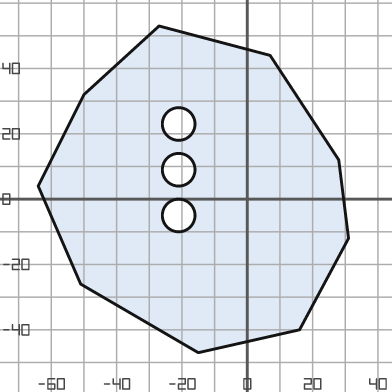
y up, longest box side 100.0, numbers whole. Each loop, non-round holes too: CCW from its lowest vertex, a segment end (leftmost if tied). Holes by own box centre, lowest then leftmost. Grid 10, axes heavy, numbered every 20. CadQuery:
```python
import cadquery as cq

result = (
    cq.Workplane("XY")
    .moveTo(-15.0, -47.0)
    .lineTo(16.0, -40.0)
    .lineTo(31.0, -12.0)
    .lineTo(28.0, 12.0)
    .lineTo(7.0, 44.0)
    .lineTo(-27.0, 53.0)
    .lineTo(-50.0, 32.0)
    .lineTo(-64.0, 4.0)
    .lineTo(-51.0, -26.0)
    .close()
    .moveTo(-21.0, -5.0)
    .circle(5.0)
    .moveTo(-21.0, 9.0)
    .circle(5.0)
    .moveTo(-21.0, 23.0)
    .circle(5.0)
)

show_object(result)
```